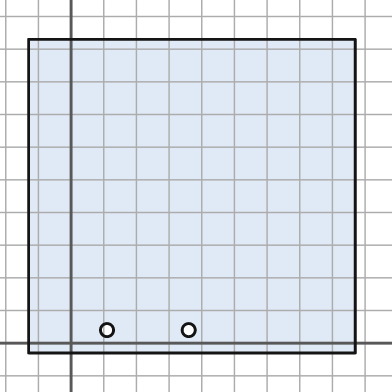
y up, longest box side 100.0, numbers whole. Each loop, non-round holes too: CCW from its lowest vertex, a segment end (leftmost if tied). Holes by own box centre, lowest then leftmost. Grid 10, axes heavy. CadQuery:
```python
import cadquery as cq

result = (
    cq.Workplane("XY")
    .moveTo(-13.0, -3.0)
    .lineTo(87.0, -3.0)
    .lineTo(87.0, 93.0)
    .lineTo(-13.0, 93.0)
    .close()
    .moveTo(11.0, 4.0)
    .circle(2.0)
    .moveTo(36.0, 4.0)
    .circle(2.0)
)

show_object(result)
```